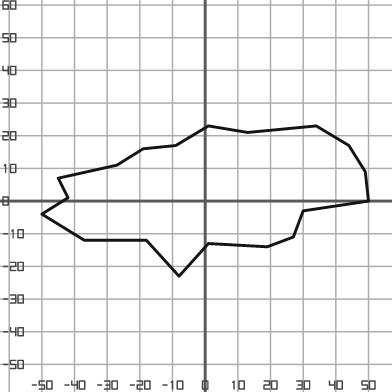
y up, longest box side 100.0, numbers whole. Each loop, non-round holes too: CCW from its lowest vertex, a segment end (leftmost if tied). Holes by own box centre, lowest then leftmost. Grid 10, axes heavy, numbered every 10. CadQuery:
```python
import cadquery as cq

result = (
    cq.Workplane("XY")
    .moveTo(-8.0, -23.0)
    .lineTo(1.0, -13.0)
    .lineTo(19.0, -14.0)
    .lineTo(27.0, -11.0)
    .lineTo(30.0, -3.0)
    .lineTo(50.0, 0.0)
    .lineTo(49.0, 9.0)
    .lineTo(44.0, 17.0)
    .lineTo(34.0, 23.0)
    .lineTo(13.0, 21.0)
    .lineTo(1.0, 23.0)
    .lineTo(-9.0, 17.0)
    .lineTo(-19.0, 16.0)
    .lineTo(-27.0, 11.0)
    .lineTo(-45.0, 7.0)
    .lineTo(-42.0, 1.0)
    .lineTo(-50.0, -4.0)
    .lineTo(-37.0, -12.0)
    .lineTo(-18.0, -12.0)
    .close()
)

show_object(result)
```